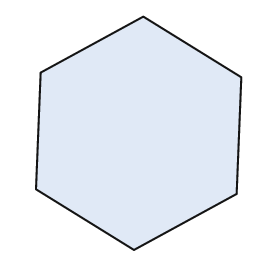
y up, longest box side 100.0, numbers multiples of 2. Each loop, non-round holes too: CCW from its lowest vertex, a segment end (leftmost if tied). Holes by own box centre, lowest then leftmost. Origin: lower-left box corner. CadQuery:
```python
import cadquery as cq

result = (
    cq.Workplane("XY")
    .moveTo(42.0, 0.0)
    .lineTo(86.0, 24.0)
    .lineTo(88.0, 74.0)
    .lineTo(46.0, 100.0)
    .lineTo(2.0, 76.0)
    .lineTo(0.0, 26.0)
    .close()
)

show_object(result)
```